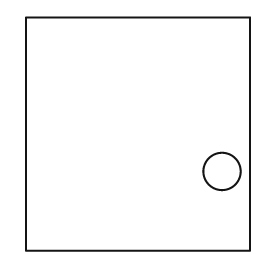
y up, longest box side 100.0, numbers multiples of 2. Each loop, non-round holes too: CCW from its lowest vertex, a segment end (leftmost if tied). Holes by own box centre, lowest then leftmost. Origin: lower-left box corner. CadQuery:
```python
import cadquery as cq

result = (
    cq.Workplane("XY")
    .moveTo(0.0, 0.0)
    .lineTo(96.0, 0.0)
    .lineTo(96.0, 100.0)
    .lineTo(0.0, 100.0)
    .close()
    .moveTo(84.0, 34.0)
    .circle(8.0)
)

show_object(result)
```